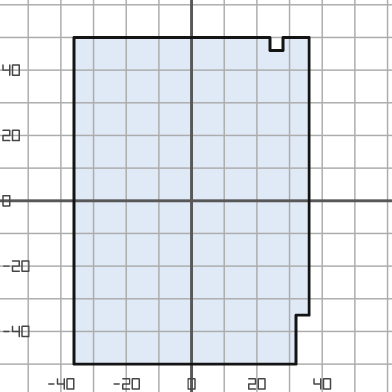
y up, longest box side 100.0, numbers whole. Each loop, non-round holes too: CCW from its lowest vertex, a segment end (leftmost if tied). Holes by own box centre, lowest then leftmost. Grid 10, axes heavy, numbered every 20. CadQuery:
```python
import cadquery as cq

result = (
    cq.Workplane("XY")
    .moveTo(-36.0, -50.0)
    .lineTo(32.0, -50.0)
    .lineTo(32.0, -35.0)
    .lineTo(36.0, -35.0)
    .lineTo(36.0, 50.0)
    .lineTo(28.0, 50.0)
    .lineTo(28.0, 46.0)
    .lineTo(24.0, 46.0)
    .lineTo(24.0, 50.0)
    .lineTo(-36.0, 50.0)
    .close()
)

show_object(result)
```